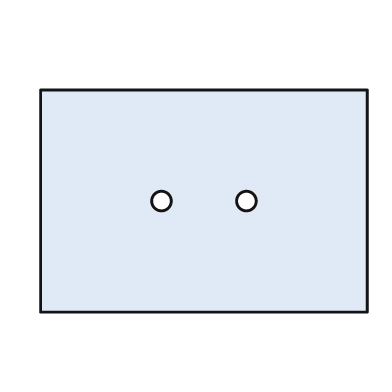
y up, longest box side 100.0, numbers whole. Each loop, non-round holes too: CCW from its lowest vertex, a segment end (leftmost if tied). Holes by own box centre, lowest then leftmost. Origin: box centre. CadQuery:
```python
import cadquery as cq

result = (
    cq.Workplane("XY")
    .moveTo(-50.0, -34.0)
    .lineTo(50.0, -34.0)
    .lineTo(50.0, 34.0)
    .lineTo(-50.0, 34.0)
    .close()
    .moveTo(-13.0, 0.0)
    .circle(3.0)
    .moveTo(13.0, 0.0)
    .circle(3.0)
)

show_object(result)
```